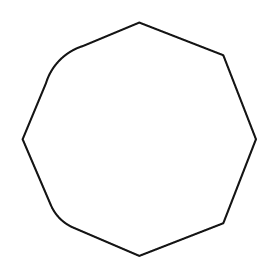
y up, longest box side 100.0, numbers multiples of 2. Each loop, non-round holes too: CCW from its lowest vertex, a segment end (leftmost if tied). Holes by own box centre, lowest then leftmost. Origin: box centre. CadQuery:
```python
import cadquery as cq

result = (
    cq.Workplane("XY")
    .moveTo(0.0, -50.0)
    .lineTo(36.0, -36.0)
    .lineTo(50.0, 0.0)
    .lineTo(36.0, 36.0)
    .lineTo(0.0, 50.0)
    .lineTo(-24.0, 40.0)
    .threePointArc((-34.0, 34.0), (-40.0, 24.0))
    .lineTo(-50.0, 0.0)
    .lineTo(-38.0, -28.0)
    .threePointArc((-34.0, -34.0), (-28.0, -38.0))
    .close()
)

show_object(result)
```